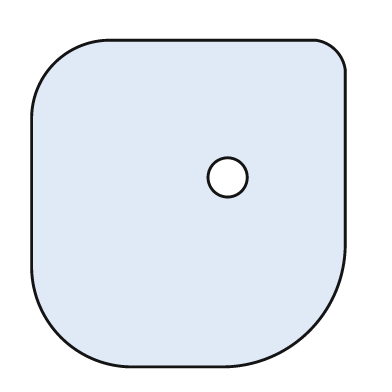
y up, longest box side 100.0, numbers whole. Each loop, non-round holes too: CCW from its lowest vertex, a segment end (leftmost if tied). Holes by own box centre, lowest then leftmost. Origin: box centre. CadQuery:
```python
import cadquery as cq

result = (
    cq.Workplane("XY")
    .moveTo(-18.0, -50.0)
    .lineTo(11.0, -50.0)
    .threePointArc((37.0, -39.0), (48.0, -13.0))
    .lineTo(48.0, 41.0)
    .threePointArc((45.0, 47.0), (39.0, 50.0))
    .lineTo(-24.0, 50.0)
    .threePointArc((-41.0, 43.0), (-48.0, 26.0))
    .lineTo(-48.0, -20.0)
    .threePointArc((-39.0, -41.0), (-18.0, -50.0))
    .close()
    .moveTo(12.0, 8.0)
    .circle(6.0)
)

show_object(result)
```